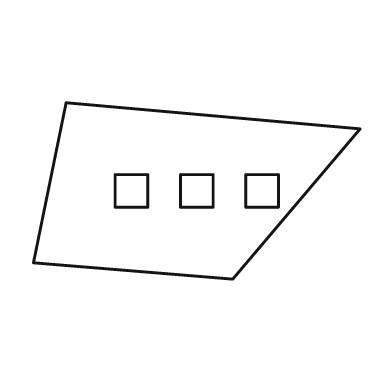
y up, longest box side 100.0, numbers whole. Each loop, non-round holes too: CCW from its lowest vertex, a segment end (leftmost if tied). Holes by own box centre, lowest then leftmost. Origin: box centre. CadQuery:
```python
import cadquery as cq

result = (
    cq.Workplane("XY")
    .moveTo(11.0, -27.0)
    .lineTo(50.0, 19.0)
    .lineTo(-40.0, 27.0)
    .lineTo(-50.0, -22.0)
    .close()
    .moveTo(-25.0, -5.0)
    .lineTo(-15.0, -5.0)
    .lineTo(-15.0, 5.0)
    .lineTo(-25.0, 5.0)
    .close()
    .moveTo(-5.0, -5.0)
    .lineTo(5.0, -5.0)
    .lineTo(5.0, 5.0)
    .lineTo(-5.0, 5.0)
    .close()
    .moveTo(15.0, -5.0)
    .lineTo(25.0, -5.0)
    .lineTo(25.0, 5.0)
    .lineTo(15.0, 5.0)
    .close()
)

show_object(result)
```